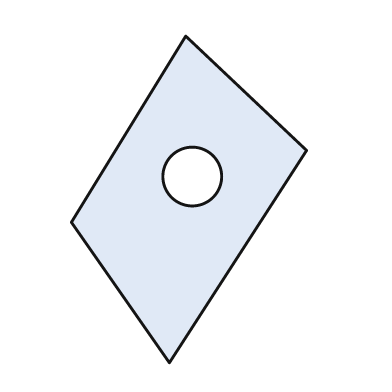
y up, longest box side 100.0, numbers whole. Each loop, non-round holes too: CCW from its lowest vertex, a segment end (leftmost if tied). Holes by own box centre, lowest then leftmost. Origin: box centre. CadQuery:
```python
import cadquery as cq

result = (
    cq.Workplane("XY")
    .moveTo(-6.0, -50.0)
    .lineTo(36.0, 15.0)
    .lineTo(-1.0, 50.0)
    .lineTo(-36.0, -7.0)
    .close()
    .moveTo(1.0, 7.0)
    .circle(9.0)
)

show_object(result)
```